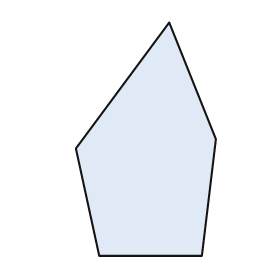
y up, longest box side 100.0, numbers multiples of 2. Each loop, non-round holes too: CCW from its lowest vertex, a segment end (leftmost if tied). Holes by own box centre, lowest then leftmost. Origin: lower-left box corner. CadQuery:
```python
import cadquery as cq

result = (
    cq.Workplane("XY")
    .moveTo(10.0, 0.0)
    .lineTo(54.0, 0.0)
    .lineTo(60.0, 50.0)
    .lineTo(40.0, 100.0)
    .lineTo(0.0, 46.0)
    .close()
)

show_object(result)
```